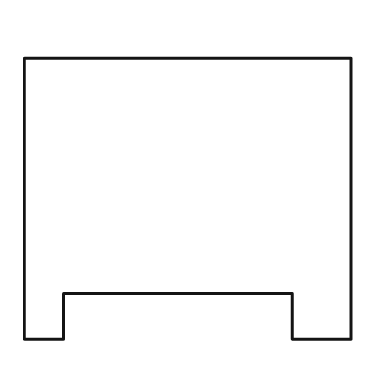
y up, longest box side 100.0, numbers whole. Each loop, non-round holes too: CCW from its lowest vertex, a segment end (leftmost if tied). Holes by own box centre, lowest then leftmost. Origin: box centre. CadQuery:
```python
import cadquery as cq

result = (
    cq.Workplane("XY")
    .moveTo(-50.0, -43.0)
    .lineTo(-38.0, -43.0)
    .lineTo(-38.0, -29.0)
    .lineTo(32.0, -29.0)
    .lineTo(32.0, -43.0)
    .lineTo(50.0, -43.0)
    .lineTo(50.0, 43.0)
    .lineTo(-50.0, 43.0)
    .close()
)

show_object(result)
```